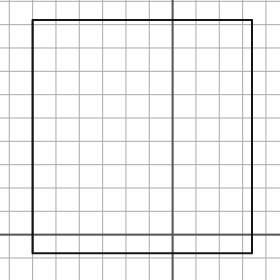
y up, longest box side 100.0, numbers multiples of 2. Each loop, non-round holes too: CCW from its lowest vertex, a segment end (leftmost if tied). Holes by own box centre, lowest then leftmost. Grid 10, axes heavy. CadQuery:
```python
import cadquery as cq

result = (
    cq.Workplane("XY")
    .moveTo(-60.0, -8.0)
    .lineTo(34.0, -8.0)
    .lineTo(34.0, 92.0)
    .lineTo(-60.0, 92.0)
    .close()
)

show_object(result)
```